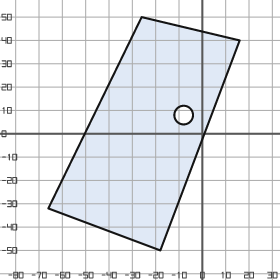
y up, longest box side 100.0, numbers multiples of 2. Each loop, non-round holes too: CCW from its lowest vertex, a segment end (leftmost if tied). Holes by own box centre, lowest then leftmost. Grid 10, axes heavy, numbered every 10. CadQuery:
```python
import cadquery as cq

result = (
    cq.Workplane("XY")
    .moveTo(-18.0, -50.0)
    .lineTo(16.0, 40.0)
    .lineTo(-26.0, 50.0)
    .lineTo(-66.0, -32.0)
    .close()
    .moveTo(-8.0, 8.0)
    .circle(4.0)
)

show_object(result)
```